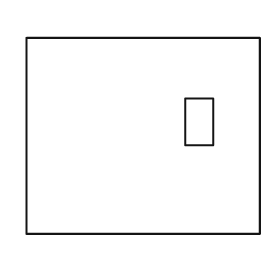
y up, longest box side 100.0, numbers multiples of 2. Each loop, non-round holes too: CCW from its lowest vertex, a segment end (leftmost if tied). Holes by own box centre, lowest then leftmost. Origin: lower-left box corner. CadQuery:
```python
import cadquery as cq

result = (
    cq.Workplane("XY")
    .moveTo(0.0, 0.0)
    .lineTo(100.0, 0.0)
    .lineTo(100.0, 84.0)
    .lineTo(0.0, 84.0)
    .close()
    .moveTo(68.0, 38.0)
    .lineTo(80.0, 38.0)
    .lineTo(80.0, 58.0)
    .lineTo(68.0, 58.0)
    .close()
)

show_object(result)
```